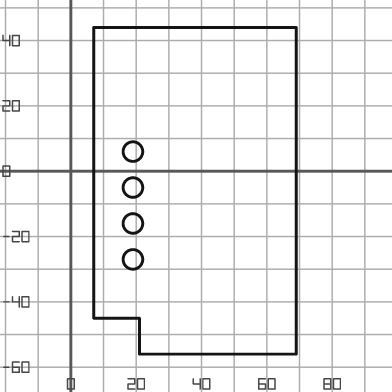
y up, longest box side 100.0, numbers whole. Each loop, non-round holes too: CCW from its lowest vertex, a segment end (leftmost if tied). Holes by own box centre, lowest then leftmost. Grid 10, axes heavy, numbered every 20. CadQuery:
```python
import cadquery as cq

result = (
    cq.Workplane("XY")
    .moveTo(21.0, -56.0)
    .lineTo(69.0, -56.0)
    .lineTo(69.0, 44.0)
    .lineTo(7.0, 44.0)
    .lineTo(7.0, -45.0)
    .lineTo(21.0, -45.0)
    .close()
    .moveTo(19.0, -27.0)
    .circle(3.0)
    .moveTo(19.0, -16.0)
    .circle(3.0)
    .moveTo(19.0, -5.0)
    .circle(3.0)
    .moveTo(19.0, 6.0)
    .circle(3.0)
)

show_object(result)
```